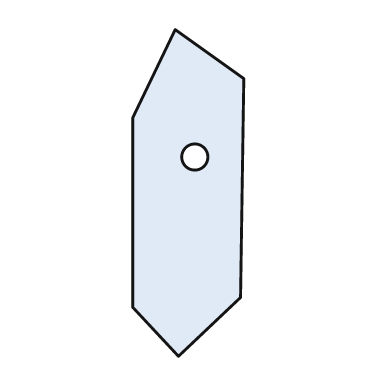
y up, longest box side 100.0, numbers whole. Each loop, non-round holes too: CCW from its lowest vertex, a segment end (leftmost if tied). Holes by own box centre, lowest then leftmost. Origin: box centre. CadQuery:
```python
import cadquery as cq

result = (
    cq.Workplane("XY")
    .moveTo(-3.0, -50.0)
    .lineTo(16.0, -32.0)
    .lineTo(17.0, 35.0)
    .lineTo(-4.0, 50.0)
    .lineTo(-17.0, 23.0)
    .lineTo(-17.0, -35.0)
    .close()
    .moveTo(2.0, 11.0)
    .circle(4.0)
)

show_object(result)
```